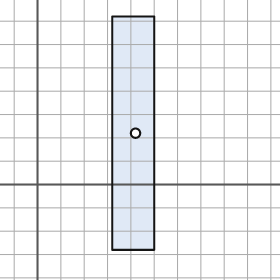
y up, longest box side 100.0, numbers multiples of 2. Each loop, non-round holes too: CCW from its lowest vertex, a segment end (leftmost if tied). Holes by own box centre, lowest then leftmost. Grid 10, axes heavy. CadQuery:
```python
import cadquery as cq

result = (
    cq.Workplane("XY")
    .moveTo(32.0, -28.0)
    .lineTo(50.0, -28.0)
    .lineTo(50.0, 72.0)
    .lineTo(32.0, 72.0)
    .close()
    .moveTo(42.0, 22.0)
    .circle(2.0)
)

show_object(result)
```